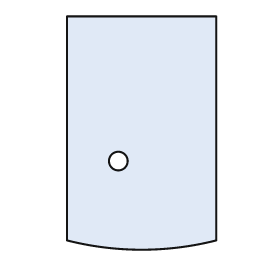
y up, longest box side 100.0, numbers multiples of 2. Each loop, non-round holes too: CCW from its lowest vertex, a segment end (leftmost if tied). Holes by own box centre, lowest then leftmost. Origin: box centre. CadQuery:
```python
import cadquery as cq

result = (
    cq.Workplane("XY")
    .moveTo(-32.0, -46.0)
    .threePointArc((0.0, -50.0), (32.0, -46.0))
    .lineTo(32.0, 50.0)
    .lineTo(-32.0, 50.0)
    .close()
    .moveTo(-10.0, -12.0)
    .circle(4.0)
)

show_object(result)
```